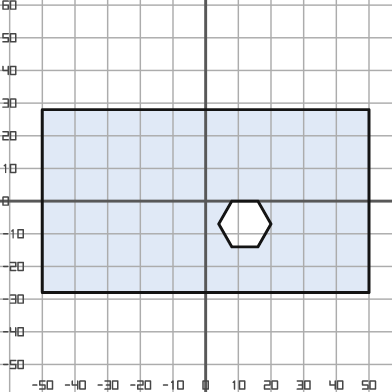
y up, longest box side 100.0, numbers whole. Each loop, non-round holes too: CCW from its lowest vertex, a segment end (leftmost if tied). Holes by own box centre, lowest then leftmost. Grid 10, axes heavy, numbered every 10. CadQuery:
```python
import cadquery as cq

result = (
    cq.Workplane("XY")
    .moveTo(-50.0, -28.0)
    .lineTo(50.0, -28.0)
    .lineTo(50.0, 28.0)
    .lineTo(-50.0, 28.0)
    .close()
    .moveTo(8.0, -14.0)
    .lineTo(16.0, -14.0)
    .lineTo(20.0, -7.0)
    .lineTo(16.0, 0.0)
    .lineTo(8.0, 0.0)
    .lineTo(4.0, -7.0)
    .close()
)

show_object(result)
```